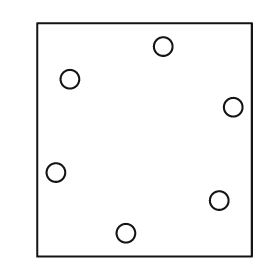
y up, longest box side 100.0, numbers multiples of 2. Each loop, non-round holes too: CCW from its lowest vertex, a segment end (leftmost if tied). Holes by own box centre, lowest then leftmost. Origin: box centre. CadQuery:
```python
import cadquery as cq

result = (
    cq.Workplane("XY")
    .moveTo(-46.0, -50.0)
    .lineTo(46.0, -50.0)
    .lineTo(46.0, 50.0)
    .lineTo(-46.0, 50.0)
    .close()
    .moveTo(-8.0, -40.0)
    .circle(4.0)
    .moveTo(32.0, -26.0)
    .circle(4.0)
    .moveTo(-38.0, -14.0)
    .circle(4.0)
    .moveTo(38.0, 14.0)
    .circle(4.0)
    .moveTo(-32.0, 26.0)
    .circle(4.0)
    .moveTo(8.0, 40.0)
    .circle(4.0)
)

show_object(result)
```